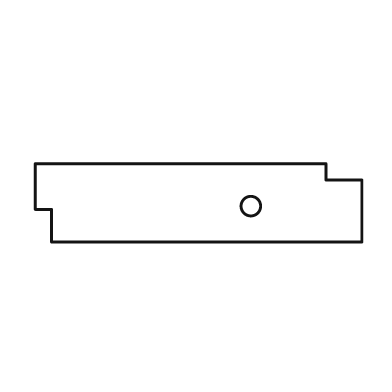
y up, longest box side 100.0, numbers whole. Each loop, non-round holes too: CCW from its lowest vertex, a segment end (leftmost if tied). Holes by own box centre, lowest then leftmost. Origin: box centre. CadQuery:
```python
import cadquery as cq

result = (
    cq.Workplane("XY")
    .moveTo(-45.0, -12.0)
    .lineTo(50.0, -12.0)
    .lineTo(50.0, 7.0)
    .lineTo(39.0, 7.0)
    .lineTo(39.0, 12.0)
    .lineTo(-50.0, 12.0)
    .lineTo(-50.0, -2.0)
    .lineTo(-45.0, -2.0)
    .close()
    .moveTo(16.0, -1.0)
    .circle(3.0)
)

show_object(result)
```